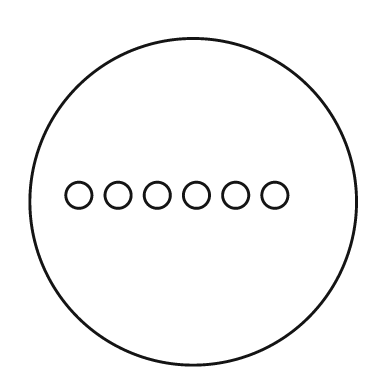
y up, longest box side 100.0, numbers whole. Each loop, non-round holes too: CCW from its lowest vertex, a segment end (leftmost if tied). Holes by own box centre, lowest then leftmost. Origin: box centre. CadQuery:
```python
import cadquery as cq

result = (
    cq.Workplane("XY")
    .moveTo(0.0, 0.0)
    .circle(50.0)
    .moveTo(-35.0, 2.0)
    .circle(4.0)
    .moveTo(-23.0, 2.0)
    .circle(4.0)
    .moveTo(-11.0, 2.0)
    .circle(4.0)
    .moveTo(1.0, 2.0)
    .circle(4.0)
    .moveTo(13.0, 2.0)
    .circle(4.0)
    .moveTo(25.0, 2.0)
    .circle(4.0)
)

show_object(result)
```